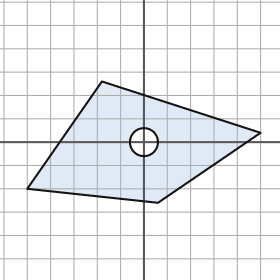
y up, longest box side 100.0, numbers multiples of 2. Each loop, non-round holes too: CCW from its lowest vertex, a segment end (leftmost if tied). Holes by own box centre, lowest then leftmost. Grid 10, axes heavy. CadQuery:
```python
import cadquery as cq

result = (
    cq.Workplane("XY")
    .moveTo(6.0, -26.0)
    .lineTo(50.0, 4.0)
    .lineTo(-18.0, 26.0)
    .lineTo(-50.0, -20.0)
    .close()
    .moveTo(0.0, 0.0)
    .circle(6.0)
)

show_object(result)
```